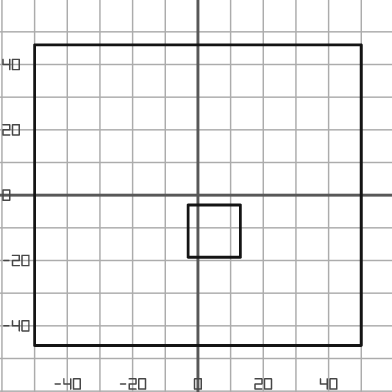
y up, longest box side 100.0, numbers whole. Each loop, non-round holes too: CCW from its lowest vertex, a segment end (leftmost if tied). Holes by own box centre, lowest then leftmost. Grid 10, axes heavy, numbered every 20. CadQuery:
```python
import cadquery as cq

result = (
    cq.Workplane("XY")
    .moveTo(-50.0, -46.0)
    .lineTo(50.0, -46.0)
    .lineTo(50.0, 46.0)
    .lineTo(-50.0, 46.0)
    .close()
    .moveTo(-3.0, -19.0)
    .lineTo(13.0, -19.0)
    .lineTo(13.0, -3.0)
    .lineTo(-3.0, -3.0)
    .close()
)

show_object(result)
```